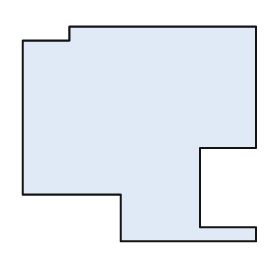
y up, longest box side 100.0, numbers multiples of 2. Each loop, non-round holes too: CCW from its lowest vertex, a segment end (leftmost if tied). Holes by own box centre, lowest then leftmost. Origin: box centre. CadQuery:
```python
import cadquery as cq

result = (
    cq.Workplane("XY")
    .moveTo(-8.0, -46.0)
    .lineTo(50.0, -46.0)
    .lineTo(50.0, -40.0)
    .lineTo(26.0, -40.0)
    .lineTo(26.0, -6.0)
    .lineTo(50.0, -6.0)
    .lineTo(50.0, 46.0)
    .lineTo(-30.0, 46.0)
    .lineTo(-30.0, 40.0)
    .lineTo(-50.0, 40.0)
    .lineTo(-50.0, -26.0)
    .lineTo(-8.0, -26.0)
    .close()
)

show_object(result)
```